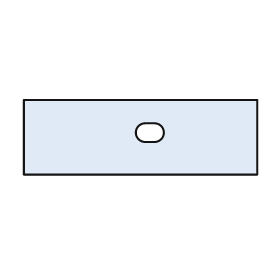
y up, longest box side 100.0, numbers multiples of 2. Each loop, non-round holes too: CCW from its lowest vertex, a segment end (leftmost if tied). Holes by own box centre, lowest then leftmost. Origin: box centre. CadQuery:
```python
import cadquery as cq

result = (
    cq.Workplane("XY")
    .moveTo(-50.0, -16.0)
    .lineTo(50.0, -16.0)
    .lineTo(50.0, 16.0)
    .lineTo(-50.0, 16.0)
    .close()
    .moveTo(2.0, -2.0)
    .lineTo(6.0, -2.0)
    .threePointArc((10.0, 2.0), (6.0, 6.0))
    .lineTo(2.0, 6.0)
    .threePointArc((-2.0, 2.0), (2.0, -2.0))
    .close()
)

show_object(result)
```